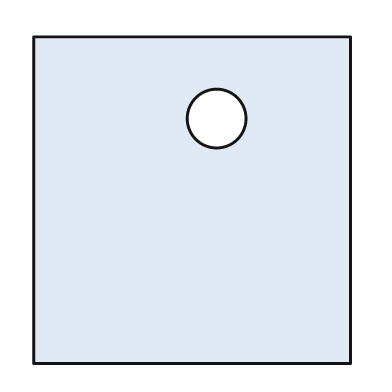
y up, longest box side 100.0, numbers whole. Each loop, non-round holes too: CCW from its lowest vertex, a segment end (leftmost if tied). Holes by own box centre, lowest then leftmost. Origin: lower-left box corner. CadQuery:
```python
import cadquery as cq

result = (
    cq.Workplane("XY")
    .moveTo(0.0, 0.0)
    .lineTo(97.0, 0.0)
    .lineTo(97.0, 100.0)
    .lineTo(0.0, 100.0)
    .close()
    .moveTo(56.0, 75.0)
    .circle(9.0)
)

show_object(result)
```